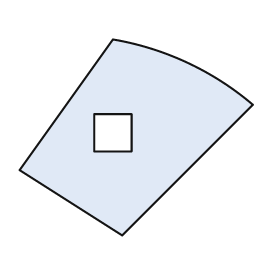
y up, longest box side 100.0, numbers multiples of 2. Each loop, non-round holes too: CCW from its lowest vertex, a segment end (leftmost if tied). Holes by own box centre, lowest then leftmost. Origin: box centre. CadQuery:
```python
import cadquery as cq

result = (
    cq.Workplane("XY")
    .moveTo(-6.0, -42.0)
    .lineTo(50.0, 14.0)
    .threePointArc((22.0, 32.0), (-10.0, 42.0))
    .lineTo(-50.0, -14.0)
    .close()
    .moveTo(-18.0, -6.0)
    .lineTo(-2.0, -6.0)
    .lineTo(-2.0, 10.0)
    .lineTo(-18.0, 10.0)
    .close()
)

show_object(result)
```